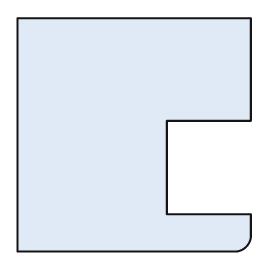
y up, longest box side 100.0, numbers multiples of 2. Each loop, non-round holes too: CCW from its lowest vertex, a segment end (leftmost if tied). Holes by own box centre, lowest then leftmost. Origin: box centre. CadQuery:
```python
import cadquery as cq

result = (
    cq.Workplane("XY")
    .moveTo(-50.0, -50.0)
    .lineTo(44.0, -50.0)
    .threePointArc((48.0, -48.0), (50.0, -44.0))
    .lineTo(50.0, -34.0)
    .lineTo(14.0, -34.0)
    .lineTo(14.0, 6.0)
    .lineTo(50.0, 6.0)
    .lineTo(50.0, 50.0)
    .lineTo(-50.0, 50.0)
    .close()
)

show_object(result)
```